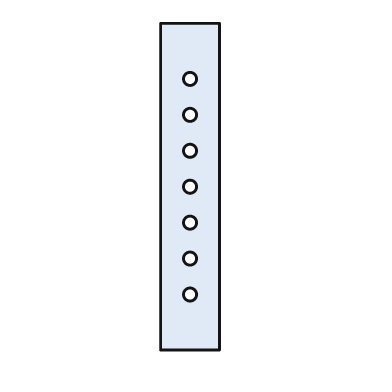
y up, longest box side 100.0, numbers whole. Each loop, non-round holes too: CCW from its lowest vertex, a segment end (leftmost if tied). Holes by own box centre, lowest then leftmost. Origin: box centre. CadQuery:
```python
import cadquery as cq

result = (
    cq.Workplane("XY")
    .moveTo(-9.0, -50.0)
    .lineTo(9.0, -50.0)
    .lineTo(9.0, 50.0)
    .lineTo(-9.0, 50.0)
    .close()
    .moveTo(0.0, -33.0)
    .circle(2.0)
    .moveTo(0.0, -22.0)
    .circle(2.0)
    .moveTo(0.0, -11.0)
    .circle(2.0)
    .moveTo(0.0, 0.0)
    .circle(2.0)
    .moveTo(0.0, 11.0)
    .circle(2.0)
    .moveTo(0.0, 22.0)
    .circle(2.0)
    .moveTo(0.0, 33.0)
    .circle(2.0)
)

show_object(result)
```